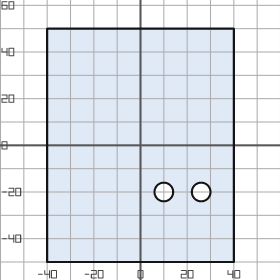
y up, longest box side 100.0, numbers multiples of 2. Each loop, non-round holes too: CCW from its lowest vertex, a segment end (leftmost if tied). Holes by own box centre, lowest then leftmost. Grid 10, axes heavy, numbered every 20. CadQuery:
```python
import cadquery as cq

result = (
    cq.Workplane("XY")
    .moveTo(-40.0, -50.0)
    .lineTo(40.0, -50.0)
    .lineTo(40.0, 50.0)
    .lineTo(-40.0, 50.0)
    .close()
    .moveTo(10.0, -20.0)
    .circle(4.0)
    .moveTo(26.0, -20.0)
    .circle(4.0)
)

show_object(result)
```